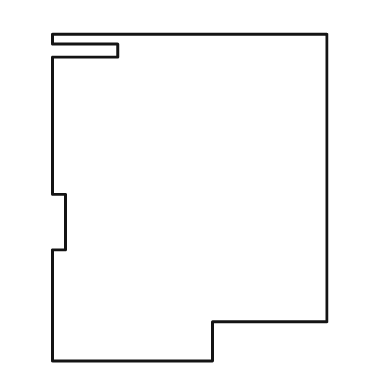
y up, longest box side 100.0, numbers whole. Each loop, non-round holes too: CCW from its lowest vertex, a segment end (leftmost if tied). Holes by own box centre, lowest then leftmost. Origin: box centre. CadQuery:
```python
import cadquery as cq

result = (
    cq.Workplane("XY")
    .moveTo(-42.0, -50.0)
    .lineTo(7.0, -50.0)
    .lineTo(7.0, -38.0)
    .lineTo(42.0, -38.0)
    .lineTo(42.0, 50.0)
    .lineTo(-42.0, 50.0)
    .lineTo(-42.0, 47.0)
    .lineTo(-22.0, 47.0)
    .lineTo(-22.0, 43.0)
    .lineTo(-42.0, 43.0)
    .lineTo(-42.0, 1.0)
    .lineTo(-38.0, 1.0)
    .lineTo(-38.0, -16.0)
    .lineTo(-42.0, -16.0)
    .close()
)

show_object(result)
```